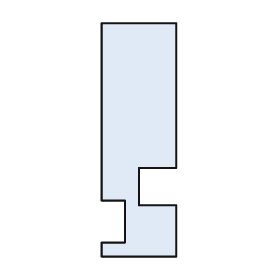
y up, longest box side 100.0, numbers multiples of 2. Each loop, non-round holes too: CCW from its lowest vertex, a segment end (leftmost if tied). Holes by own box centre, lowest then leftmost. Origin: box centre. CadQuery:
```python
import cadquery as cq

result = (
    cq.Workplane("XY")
    .moveTo(-16.0, -50.0)
    .lineTo(16.0, -50.0)
    .lineTo(16.0, -28.0)
    .lineTo(0.0, -28.0)
    .lineTo(0.0, -12.0)
    .lineTo(16.0, -12.0)
    .lineTo(16.0, 50.0)
    .lineTo(-16.0, 50.0)
    .lineTo(-16.0, -26.0)
    .lineTo(-6.0, -26.0)
    .lineTo(-6.0, -44.0)
    .lineTo(-16.0, -44.0)
    .close()
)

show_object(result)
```